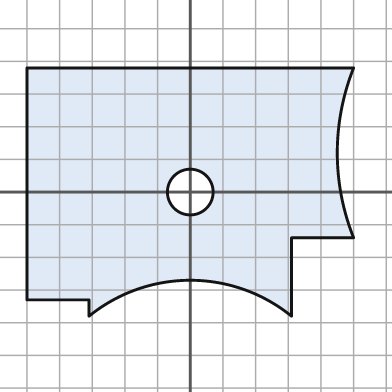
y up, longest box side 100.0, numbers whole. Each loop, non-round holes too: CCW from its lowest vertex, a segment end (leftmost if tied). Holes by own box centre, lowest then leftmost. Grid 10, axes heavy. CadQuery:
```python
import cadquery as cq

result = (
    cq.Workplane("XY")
    .moveTo(-31.0, -38.0)
    .threePointArc((0.0, -27.0), (31.0, -38.0))
    .lineTo(31.0, -14.0)
    .lineTo(50.0, -14.0)
    .threePointArc((45.0, 12.0), (50.0, 38.0))
    .lineTo(-50.0, 38.0)
    .lineTo(-50.0, -33.0)
    .lineTo(-31.0, -33.0)
    .close()
    .moveTo(0.0, 0.0)
    .circle(7.0)
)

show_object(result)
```